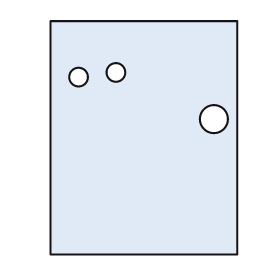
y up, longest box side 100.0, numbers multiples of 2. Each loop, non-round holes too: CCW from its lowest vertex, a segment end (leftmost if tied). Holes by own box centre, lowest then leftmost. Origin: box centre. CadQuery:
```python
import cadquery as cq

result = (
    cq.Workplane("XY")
    .moveTo(-40.0, -50.0)
    .lineTo(40.0, -50.0)
    .lineTo(40.0, 50.0)
    .lineTo(-40.0, 50.0)
    .close()
    .moveTo(30.0, 8.0)
    .circle(6.0)
    .moveTo(-28.0, 26.0)
    .circle(4.0)
    .moveTo(-12.0, 28.0)
    .circle(4.0)
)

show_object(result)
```